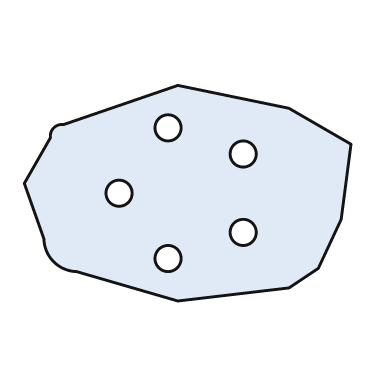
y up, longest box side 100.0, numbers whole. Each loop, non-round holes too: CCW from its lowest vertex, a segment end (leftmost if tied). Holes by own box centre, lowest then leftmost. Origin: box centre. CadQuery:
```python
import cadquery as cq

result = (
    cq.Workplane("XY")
    .moveTo(-3.0, -33.0)
    .lineTo(31.0, -29.0)
    .lineTo(40.0, -23.0)
    .lineTo(47.0, -8.0)
    .lineTo(50.0, 15.0)
    .lineTo(31.0, 26.0)
    .lineTo(-3.0, 33.0)
    .lineTo(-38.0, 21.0)
    .threePointArc((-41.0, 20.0), (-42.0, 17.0))
    .lineTo(-50.0, 3.0)
    .lineTo(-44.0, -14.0)
    .threePointArc((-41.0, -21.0), (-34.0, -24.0))
    .close()
    .moveTo(-6.0, -20.0)
    .circle(4.0)
    .moveTo(17.0, -12.0)
    .circle(4.0)
    .moveTo(-21.0, 0.0)
    .circle(4.0)
    .moveTo(17.0, 12.0)
    .circle(4.0)
    .moveTo(-6.0, 20.0)
    .circle(4.0)
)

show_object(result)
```